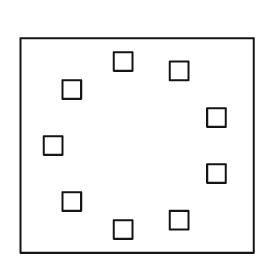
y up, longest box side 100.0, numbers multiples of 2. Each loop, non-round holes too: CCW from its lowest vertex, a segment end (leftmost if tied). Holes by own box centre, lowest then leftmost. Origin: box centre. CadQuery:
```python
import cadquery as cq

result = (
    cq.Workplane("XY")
    .moveTo(-50.0, -46.0)
    .lineTo(50.0, -46.0)
    .lineTo(50.0, 46.0)
    .lineTo(-50.0, 46.0)
    .close()
    .moveTo(-10.0, -40.0)
    .lineTo(-2.0, -40.0)
    .lineTo(-2.0, -32.0)
    .lineTo(-10.0, -32.0)
    .close()
    .moveTo(14.0, -36.0)
    .lineTo(22.0, -36.0)
    .lineTo(22.0, -28.0)
    .lineTo(14.0, -28.0)
    .close()
    .moveTo(-32.0, -28.0)
    .lineTo(-24.0, -28.0)
    .lineTo(-24.0, -20.0)
    .lineTo(-32.0, -20.0)
    .close()
    .moveTo(30.0, -16.0)
    .lineTo(38.0, -16.0)
    .lineTo(38.0, -8.0)
    .lineTo(30.0, -8.0)
    .close()
    .moveTo(-40.0, -4.0)
    .lineTo(-32.0, -4.0)
    .lineTo(-32.0, 4.0)
    .lineTo(-40.0, 4.0)
    .close()
    .moveTo(30.0, 8.0)
    .lineTo(38.0, 8.0)
    .lineTo(38.0, 16.0)
    .lineTo(30.0, 16.0)
    .close()
    .moveTo(-32.0, 20.0)
    .lineTo(-24.0, 20.0)
    .lineTo(-24.0, 28.0)
    .lineTo(-32.0, 28.0)
    .close()
    .moveTo(14.0, 28.0)
    .lineTo(22.0, 28.0)
    .lineTo(22.0, 36.0)
    .lineTo(14.0, 36.0)
    .close()
    .moveTo(-10.0, 32.0)
    .lineTo(-2.0, 32.0)
    .lineTo(-2.0, 40.0)
    .lineTo(-10.0, 40.0)
    .close()
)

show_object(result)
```